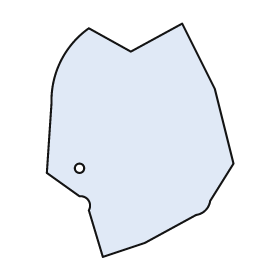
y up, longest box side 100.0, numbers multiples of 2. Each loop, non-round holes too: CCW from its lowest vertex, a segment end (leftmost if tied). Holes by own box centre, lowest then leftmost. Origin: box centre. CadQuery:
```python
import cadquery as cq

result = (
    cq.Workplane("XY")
    .moveTo(-16.0, -50.0)
    .lineTo(2.0, -44.0)
    .lineTo(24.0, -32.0)
    .threePointArc((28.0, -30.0), (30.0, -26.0))
    .lineTo(40.0, -10.0)
    .lineTo(32.0, 22.0)
    .lineTo(18.0, 50.0)
    .lineTo(-4.0, 38.0)
    .lineTo(-22.0, 48.0)
    .threePointArc((-34.0, 34.0), (-38.0, 16.0))
    .lineTo(-40.0, -14.0)
    .lineTo(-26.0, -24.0)
    .threePointArc((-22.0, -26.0), (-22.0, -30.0))
    .close()
    .moveTo(-26.0, -12.0)
    .circle(2.0)
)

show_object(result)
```